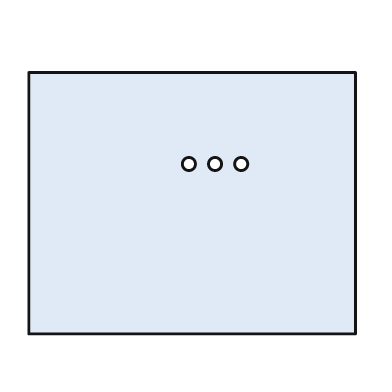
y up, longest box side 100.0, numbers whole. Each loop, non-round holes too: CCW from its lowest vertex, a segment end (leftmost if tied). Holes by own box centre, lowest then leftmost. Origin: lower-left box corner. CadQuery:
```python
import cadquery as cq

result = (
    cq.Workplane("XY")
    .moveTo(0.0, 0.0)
    .lineTo(100.0, 0.0)
    .lineTo(100.0, 80.0)
    .lineTo(0.0, 80.0)
    .close()
    .moveTo(49.0, 52.0)
    .circle(2.0)
    .moveTo(57.0, 52.0)
    .circle(2.0)
    .moveTo(65.0, 52.0)
    .circle(2.0)
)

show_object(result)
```